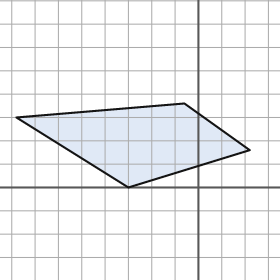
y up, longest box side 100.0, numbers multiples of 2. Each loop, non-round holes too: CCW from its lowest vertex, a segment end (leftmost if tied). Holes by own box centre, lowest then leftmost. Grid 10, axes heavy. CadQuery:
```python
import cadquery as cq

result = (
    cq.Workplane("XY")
    .moveTo(-30.0, 0.0)
    .lineTo(22.0, 16.0)
    .lineTo(-6.0, 36.0)
    .lineTo(-78.0, 30.0)
    .close()
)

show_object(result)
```